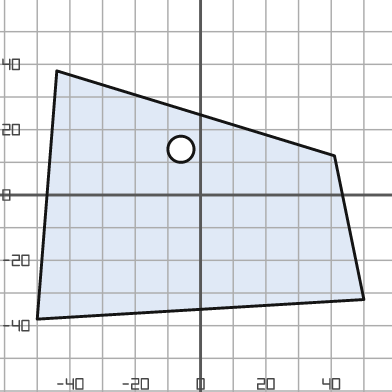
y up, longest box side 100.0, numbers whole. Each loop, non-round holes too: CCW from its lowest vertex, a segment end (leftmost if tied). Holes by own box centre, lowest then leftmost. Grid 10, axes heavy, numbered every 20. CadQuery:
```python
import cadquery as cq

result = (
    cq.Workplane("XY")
    .moveTo(-50.0, -38.0)
    .lineTo(50.0, -32.0)
    .lineTo(41.0, 12.0)
    .lineTo(-44.0, 38.0)
    .close()
    .moveTo(-6.0, 14.0)
    .circle(4.0)
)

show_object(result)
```